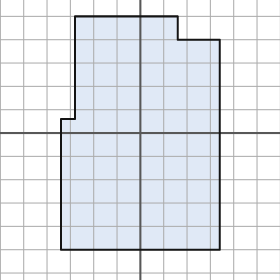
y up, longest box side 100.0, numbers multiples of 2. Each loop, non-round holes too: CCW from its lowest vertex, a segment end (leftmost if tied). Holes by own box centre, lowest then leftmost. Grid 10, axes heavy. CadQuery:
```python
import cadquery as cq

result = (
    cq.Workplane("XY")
    .moveTo(-34.0, -50.0)
    .lineTo(34.0, -50.0)
    .lineTo(34.0, 40.0)
    .lineTo(16.0, 40.0)
    .lineTo(16.0, 50.0)
    .lineTo(-28.0, 50.0)
    .lineTo(-28.0, 6.0)
    .lineTo(-34.0, 6.0)
    .close()
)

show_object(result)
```